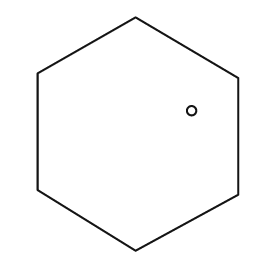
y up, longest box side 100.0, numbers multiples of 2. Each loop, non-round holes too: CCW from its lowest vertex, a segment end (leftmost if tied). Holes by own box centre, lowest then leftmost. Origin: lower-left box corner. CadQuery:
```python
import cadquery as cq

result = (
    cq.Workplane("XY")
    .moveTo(42.0, 0.0)
    .lineTo(86.0, 24.0)
    .lineTo(86.0, 74.0)
    .lineTo(42.0, 100.0)
    .lineTo(0.0, 76.0)
    .lineTo(0.0, 26.0)
    .close()
    .moveTo(66.0, 60.0)
    .circle(2.0)
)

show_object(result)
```